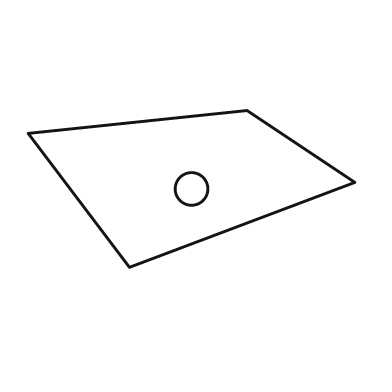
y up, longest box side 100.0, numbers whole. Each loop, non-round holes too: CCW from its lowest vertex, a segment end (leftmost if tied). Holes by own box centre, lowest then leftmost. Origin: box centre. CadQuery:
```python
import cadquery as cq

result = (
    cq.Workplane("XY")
    .moveTo(-19.0, -24.0)
    .lineTo(50.0, 2.0)
    .lineTo(17.0, 24.0)
    .lineTo(-50.0, 17.0)
    .close()
    .moveTo(0.0, 0.0)
    .circle(5.0)
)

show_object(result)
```